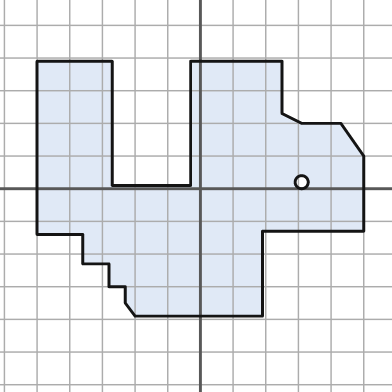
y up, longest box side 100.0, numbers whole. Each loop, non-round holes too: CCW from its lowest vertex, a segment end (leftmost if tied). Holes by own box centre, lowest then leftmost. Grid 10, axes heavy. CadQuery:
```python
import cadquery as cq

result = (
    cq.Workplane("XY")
    .moveTo(-20.0, -39.0)
    .lineTo(19.0, -39.0)
    .lineTo(19.0, -13.0)
    .lineTo(50.0, -13.0)
    .lineTo(50.0, 10.0)
    .lineTo(43.0, 20.0)
    .lineTo(31.0, 20.0)
    .lineTo(25.0, 23.0)
    .lineTo(25.0, 39.0)
    .lineTo(-3.0, 39.0)
    .lineTo(-3.0, 1.0)
    .lineTo(-27.0, 1.0)
    .lineTo(-27.0, 39.0)
    .lineTo(-50.0, 39.0)
    .lineTo(-50.0, -14.0)
    .lineTo(-36.0, -14.0)
    .lineTo(-36.0, -23.0)
    .lineTo(-28.0, -23.0)
    .lineTo(-28.0, -30.0)
    .lineTo(-23.0, -30.0)
    .lineTo(-23.0, -35.0)
    .close()
    .moveTo(31.0, 2.0)
    .circle(2.0)
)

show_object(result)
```